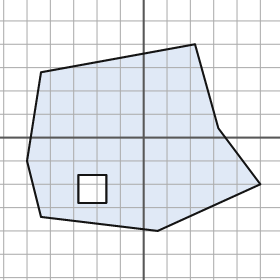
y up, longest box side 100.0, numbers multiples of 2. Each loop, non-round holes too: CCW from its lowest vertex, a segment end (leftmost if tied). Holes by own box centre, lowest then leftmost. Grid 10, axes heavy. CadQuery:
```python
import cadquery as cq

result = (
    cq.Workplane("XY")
    .moveTo(6.0, -40.0)
    .lineTo(50.0, -20.0)
    .lineTo(32.0, 4.0)
    .lineTo(22.0, 40.0)
    .lineTo(-44.0, 28.0)
    .lineTo(-50.0, -10.0)
    .lineTo(-44.0, -34.0)
    .close()
    .moveTo(-28.0, -28.0)
    .lineTo(-16.0, -28.0)
    .lineTo(-16.0, -16.0)
    .lineTo(-28.0, -16.0)
    .close()
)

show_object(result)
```